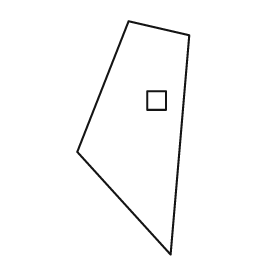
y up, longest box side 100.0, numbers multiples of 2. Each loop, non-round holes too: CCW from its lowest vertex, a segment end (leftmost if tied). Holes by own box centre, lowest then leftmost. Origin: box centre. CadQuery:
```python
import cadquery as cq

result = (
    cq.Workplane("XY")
    .moveTo(16.0, -50.0)
    .lineTo(24.0, 44.0)
    .lineTo(-2.0, 50.0)
    .lineTo(-24.0, -6.0)
    .close()
    .moveTo(6.0, 12.0)
    .lineTo(14.0, 12.0)
    .lineTo(14.0, 20.0)
    .lineTo(6.0, 20.0)
    .close()
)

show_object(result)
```